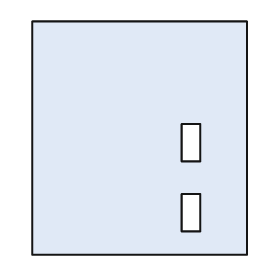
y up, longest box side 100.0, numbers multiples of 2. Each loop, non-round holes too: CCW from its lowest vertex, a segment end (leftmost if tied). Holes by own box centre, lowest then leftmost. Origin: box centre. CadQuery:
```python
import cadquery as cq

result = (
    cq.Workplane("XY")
    .moveTo(-46.0, -50.0)
    .lineTo(46.0, -50.0)
    .lineTo(46.0, 50.0)
    .lineTo(-46.0, 50.0)
    .close()
    .moveTo(18.0, -40.0)
    .lineTo(26.0, -40.0)
    .lineTo(26.0, -24.0)
    .lineTo(18.0, -24.0)
    .close()
    .moveTo(18.0, -10.0)
    .lineTo(26.0, -10.0)
    .lineTo(26.0, 6.0)
    .lineTo(18.0, 6.0)
    .close()
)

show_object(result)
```